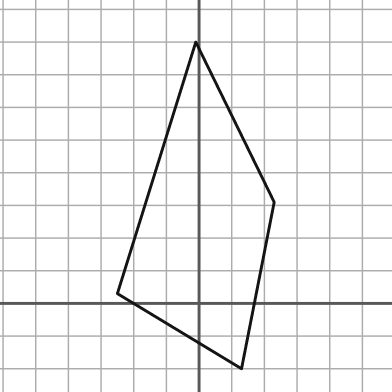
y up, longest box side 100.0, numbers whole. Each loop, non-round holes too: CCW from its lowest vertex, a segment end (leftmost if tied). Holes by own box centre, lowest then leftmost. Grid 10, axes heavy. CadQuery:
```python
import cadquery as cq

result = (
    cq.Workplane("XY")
    .moveTo(13.0, -20.0)
    .lineTo(23.0, 31.0)
    .lineTo(-1.0, 80.0)
    .lineTo(-25.0, 3.0)
    .close()
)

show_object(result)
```